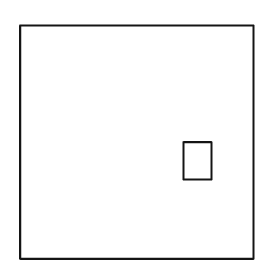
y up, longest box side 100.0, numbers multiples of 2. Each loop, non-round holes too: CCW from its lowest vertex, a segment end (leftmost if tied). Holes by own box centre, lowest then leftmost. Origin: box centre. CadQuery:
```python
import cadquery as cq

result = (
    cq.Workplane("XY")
    .moveTo(-50.0, -50.0)
    .lineTo(50.0, -50.0)
    .lineTo(50.0, 50.0)
    .lineTo(-50.0, 50.0)
    .close()
    .moveTo(20.0, -16.0)
    .lineTo(32.0, -16.0)
    .lineTo(32.0, 0.0)
    .lineTo(20.0, 0.0)
    .close()
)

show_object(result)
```